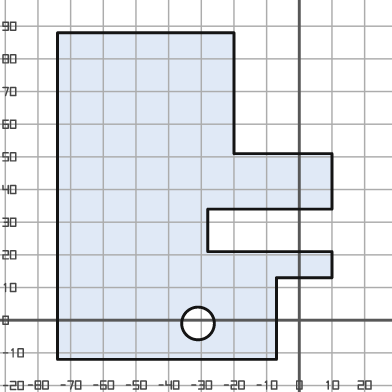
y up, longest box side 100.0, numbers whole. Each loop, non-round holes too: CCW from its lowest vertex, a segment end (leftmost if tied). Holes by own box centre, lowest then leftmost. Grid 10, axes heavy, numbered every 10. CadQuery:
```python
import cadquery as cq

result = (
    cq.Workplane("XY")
    .moveTo(-74.0, -12.0)
    .lineTo(-7.0, -12.0)
    .lineTo(-7.0, 13.0)
    .lineTo(10.0, 13.0)
    .lineTo(10.0, 21.0)
    .lineTo(-28.0, 21.0)
    .lineTo(-28.0, 34.0)
    .lineTo(10.0, 34.0)
    .lineTo(10.0, 51.0)
    .lineTo(-20.0, 51.0)
    .lineTo(-20.0, 88.0)
    .lineTo(-74.0, 88.0)
    .close()
    .moveTo(-31.0, -1.0)
    .circle(5.0)
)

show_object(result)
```